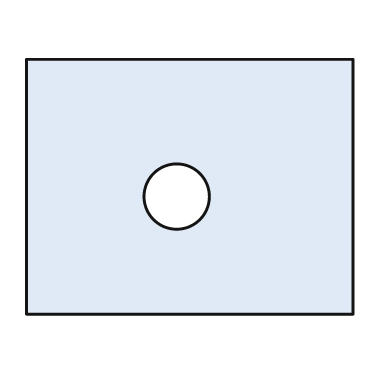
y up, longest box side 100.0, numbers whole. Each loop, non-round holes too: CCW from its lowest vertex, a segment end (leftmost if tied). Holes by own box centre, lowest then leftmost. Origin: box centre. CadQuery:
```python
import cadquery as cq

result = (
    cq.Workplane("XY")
    .moveTo(-50.0, -39.0)
    .lineTo(50.0, -39.0)
    .lineTo(50.0, 39.0)
    .lineTo(-50.0, 39.0)
    .close()
    .moveTo(-4.0, -3.0)
    .circle(10.0)
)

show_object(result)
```